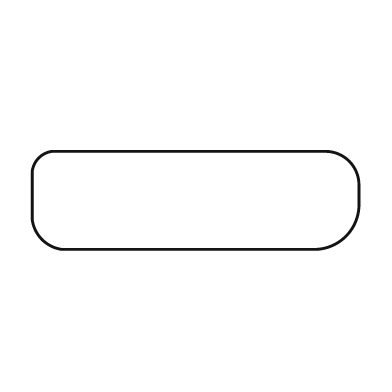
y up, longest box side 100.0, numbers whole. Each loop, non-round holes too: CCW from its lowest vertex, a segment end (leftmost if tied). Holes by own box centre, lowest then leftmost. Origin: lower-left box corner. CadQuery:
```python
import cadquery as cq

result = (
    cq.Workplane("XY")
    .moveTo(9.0, 0.0)
    .lineTo(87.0, 0.0)
    .threePointArc((96.0, 4.0), (100.0, 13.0))
    .lineTo(100.0, 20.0)
    .threePointArc((97.0, 27.0), (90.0, 30.0))
    .lineTo(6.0, 30.0)
    .threePointArc((2.0, 28.0), (0.0, 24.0))
    .lineTo(0.0, 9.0)
    .threePointArc((3.0, 3.0), (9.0, 0.0))
    .close()
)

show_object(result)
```